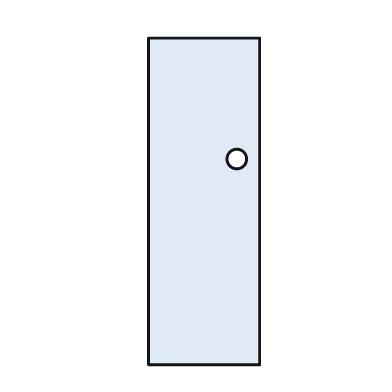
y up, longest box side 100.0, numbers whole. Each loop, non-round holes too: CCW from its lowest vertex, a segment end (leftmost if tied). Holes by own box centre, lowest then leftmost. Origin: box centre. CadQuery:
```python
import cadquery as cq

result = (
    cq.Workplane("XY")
    .moveTo(-17.0, -50.0)
    .lineTo(17.0, -50.0)
    .lineTo(17.0, 50.0)
    .lineTo(-17.0, 50.0)
    .close()
    .moveTo(10.0, 13.0)
    .circle(3.0)
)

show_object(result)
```